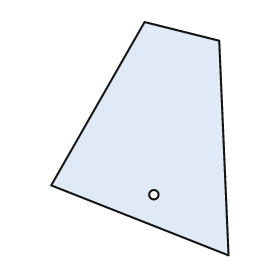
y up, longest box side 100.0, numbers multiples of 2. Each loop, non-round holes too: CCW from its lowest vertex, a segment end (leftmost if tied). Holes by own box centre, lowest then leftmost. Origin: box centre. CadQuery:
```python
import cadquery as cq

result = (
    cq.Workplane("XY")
    .moveTo(38.0, -50.0)
    .lineTo(34.0, 42.0)
    .lineTo(2.0, 50.0)
    .lineTo(-38.0, -20.0)
    .close()
    .moveTo(6.0, -24.0)
    .circle(2.0)
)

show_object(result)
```